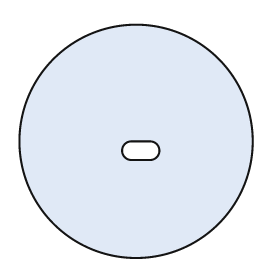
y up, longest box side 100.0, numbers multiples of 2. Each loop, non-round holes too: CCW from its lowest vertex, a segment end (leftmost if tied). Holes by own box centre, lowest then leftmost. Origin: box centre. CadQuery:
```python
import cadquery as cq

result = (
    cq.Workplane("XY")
    .moveTo(0.0, 0.0)
    .circle(50.0)
    .moveTo(-2.0, -8.0)
    .lineTo(6.0, -8.0)
    .threePointArc((10.0, -4.0), (6.0, 0.0))
    .lineTo(-2.0, 0.0)
    .threePointArc((-6.0, -4.0), (-2.0, -8.0))
    .close()
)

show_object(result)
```